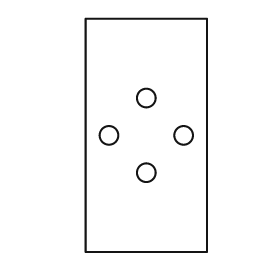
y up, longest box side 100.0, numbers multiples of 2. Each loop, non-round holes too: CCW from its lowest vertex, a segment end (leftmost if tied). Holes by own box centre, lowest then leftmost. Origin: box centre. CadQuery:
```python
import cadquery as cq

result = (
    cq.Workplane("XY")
    .moveTo(-26.0, -50.0)
    .lineTo(26.0, -50.0)
    .lineTo(26.0, 50.0)
    .lineTo(-26.0, 50.0)
    .close()
    .moveTo(0.0, -16.0)
    .circle(4.0)
    .moveTo(-16.0, 0.0)
    .circle(4.0)
    .moveTo(16.0, 0.0)
    .circle(4.0)
    .moveTo(0.0, 16.0)
    .circle(4.0)
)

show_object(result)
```